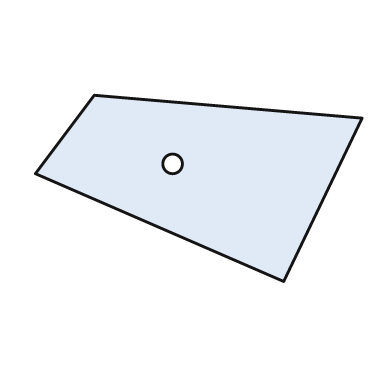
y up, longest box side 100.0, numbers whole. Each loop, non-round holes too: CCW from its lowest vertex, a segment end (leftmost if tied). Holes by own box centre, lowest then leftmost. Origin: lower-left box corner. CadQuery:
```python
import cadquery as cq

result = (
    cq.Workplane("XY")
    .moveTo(76.0, 0.0)
    .lineTo(100.0, 50.0)
    .lineTo(18.0, 57.0)
    .lineTo(0.0, 33.0)
    .close()
    .moveTo(42.0, 36.0)
    .circle(3.0)
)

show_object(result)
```